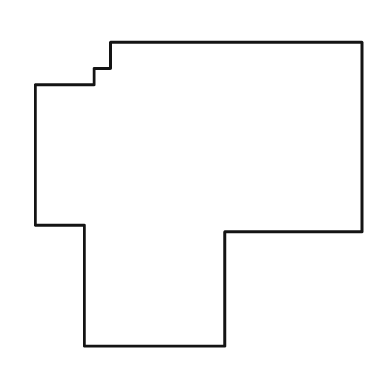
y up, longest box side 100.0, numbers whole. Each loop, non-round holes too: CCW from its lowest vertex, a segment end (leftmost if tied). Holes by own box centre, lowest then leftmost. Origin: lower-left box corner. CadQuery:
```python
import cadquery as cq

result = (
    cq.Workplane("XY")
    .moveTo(15.0, 0.0)
    .lineTo(58.0, 0.0)
    .lineTo(58.0, 35.0)
    .lineTo(100.0, 35.0)
    .lineTo(100.0, 93.0)
    .lineTo(23.0, 93.0)
    .lineTo(23.0, 85.0)
    .lineTo(18.0, 85.0)
    .lineTo(18.0, 80.0)
    .lineTo(0.0, 80.0)
    .lineTo(0.0, 37.0)
    .lineTo(15.0, 37.0)
    .close()
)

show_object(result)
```